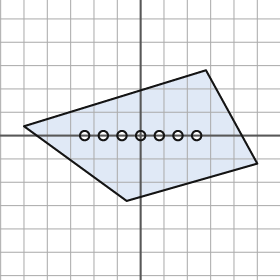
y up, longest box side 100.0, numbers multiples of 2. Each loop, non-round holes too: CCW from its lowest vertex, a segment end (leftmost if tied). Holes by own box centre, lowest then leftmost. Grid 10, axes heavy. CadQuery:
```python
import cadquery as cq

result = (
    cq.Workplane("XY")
    .moveTo(-6.0, -28.0)
    .lineTo(50.0, -12.0)
    .lineTo(28.0, 28.0)
    .lineTo(-50.0, 4.0)
    .close()
    .moveTo(-24.0, 0.0)
    .circle(2.0)
    .moveTo(-16.0, 0.0)
    .circle(2.0)
    .moveTo(-8.0, 0.0)
    .circle(2.0)
    .moveTo(0.0, 0.0)
    .circle(2.0)
    .moveTo(8.0, 0.0)
    .circle(2.0)
    .moveTo(16.0, 0.0)
    .circle(2.0)
    .moveTo(24.0, 0.0)
    .circle(2.0)
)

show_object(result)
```